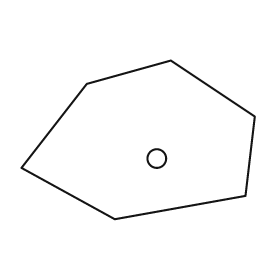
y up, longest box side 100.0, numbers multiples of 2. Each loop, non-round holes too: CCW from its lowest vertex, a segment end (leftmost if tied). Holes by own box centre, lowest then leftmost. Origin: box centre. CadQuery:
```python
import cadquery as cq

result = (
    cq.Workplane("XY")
    .moveTo(-10.0, -34.0)
    .lineTo(46.0, -24.0)
    .lineTo(50.0, 10.0)
    .lineTo(14.0, 34.0)
    .lineTo(-22.0, 24.0)
    .lineTo(-50.0, -12.0)
    .close()
    .moveTo(8.0, -8.0)
    .circle(4.0)
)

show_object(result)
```